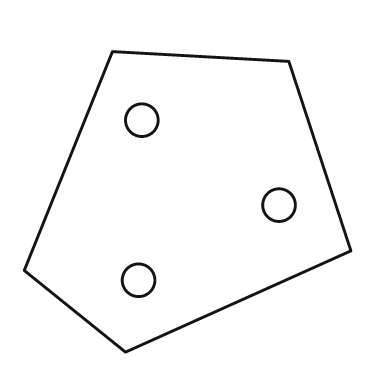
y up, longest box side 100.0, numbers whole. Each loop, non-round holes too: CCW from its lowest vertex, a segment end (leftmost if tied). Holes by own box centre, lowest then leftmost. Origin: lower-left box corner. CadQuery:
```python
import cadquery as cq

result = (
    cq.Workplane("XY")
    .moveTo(31.0, 0.0)
    .lineTo(100.0, 31.0)
    .lineTo(81.0, 89.0)
    .lineTo(27.0, 92.0)
    .lineTo(0.0, 25.0)
    .close()
    .moveTo(35.0, 22.0)
    .circle(5.0)
    .moveTo(78.0, 45.0)
    .circle(5.0)
    .moveTo(36.0, 71.0)
    .circle(5.0)
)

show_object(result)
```